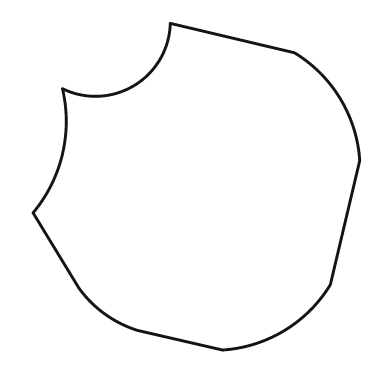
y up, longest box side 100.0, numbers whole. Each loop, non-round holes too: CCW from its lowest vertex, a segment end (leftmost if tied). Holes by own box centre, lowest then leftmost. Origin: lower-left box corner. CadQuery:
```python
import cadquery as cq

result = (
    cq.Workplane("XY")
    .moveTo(58.0, 0.0)
    .threePointArc((77.0, 6.0), (91.0, 20.0))
    .lineTo(100.0, 58.0)
    .threePointArc((94.0, 77.0), (80.0, 91.0))
    .lineTo(42.0, 100.0)
    .threePointArc((31.0, 81.0), (9.0, 80.0))
    .threePointArc((9.0, 60.0), (0.0, 42.0))
    .lineTo(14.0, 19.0)
    .threePointArc((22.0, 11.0), (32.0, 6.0))
    .close()
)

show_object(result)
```